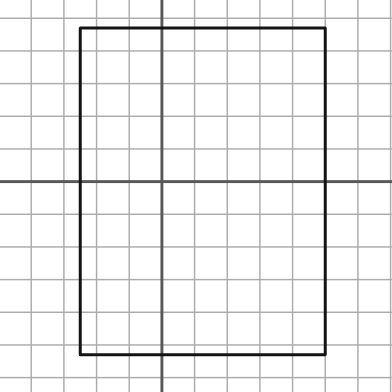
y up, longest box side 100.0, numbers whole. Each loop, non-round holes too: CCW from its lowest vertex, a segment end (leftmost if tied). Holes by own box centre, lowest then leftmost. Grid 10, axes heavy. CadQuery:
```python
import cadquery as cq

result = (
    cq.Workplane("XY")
    .moveTo(-25.0, -53.0)
    .lineTo(50.0, -53.0)
    .lineTo(50.0, 47.0)
    .lineTo(-25.0, 47.0)
    .close()
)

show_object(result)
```